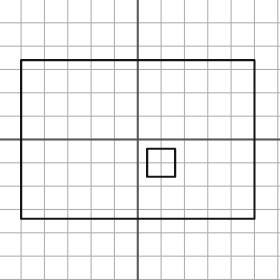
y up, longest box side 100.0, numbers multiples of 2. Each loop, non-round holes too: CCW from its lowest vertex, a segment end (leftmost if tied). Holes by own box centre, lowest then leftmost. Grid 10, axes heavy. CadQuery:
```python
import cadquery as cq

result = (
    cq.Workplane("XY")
    .moveTo(-50.0, -34.0)
    .lineTo(50.0, -34.0)
    .lineTo(50.0, 34.0)
    .lineTo(-50.0, 34.0)
    .close()
    .moveTo(4.0, -16.0)
    .lineTo(16.0, -16.0)
    .lineTo(16.0, -4.0)
    .lineTo(4.0, -4.0)
    .close()
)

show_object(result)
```